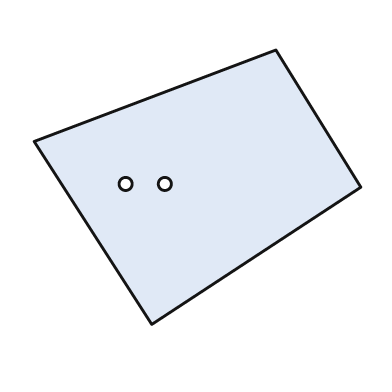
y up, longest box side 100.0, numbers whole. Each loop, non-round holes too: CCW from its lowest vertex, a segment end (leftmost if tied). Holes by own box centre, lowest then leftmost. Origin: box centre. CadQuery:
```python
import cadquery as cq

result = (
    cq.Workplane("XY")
    .moveTo(-14.0, -42.0)
    .lineTo(50.0, 0.0)
    .lineTo(24.0, 42.0)
    .lineTo(-50.0, 14.0)
    .close()
    .moveTo(-22.0, 1.0)
    .circle(2.0)
    .moveTo(-10.0, 1.0)
    .circle(2.0)
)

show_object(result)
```